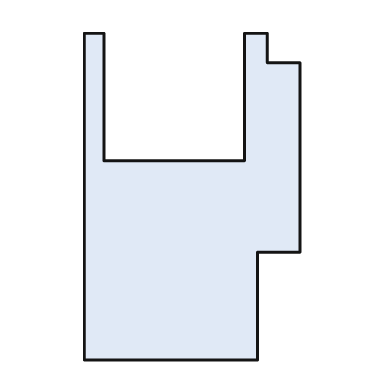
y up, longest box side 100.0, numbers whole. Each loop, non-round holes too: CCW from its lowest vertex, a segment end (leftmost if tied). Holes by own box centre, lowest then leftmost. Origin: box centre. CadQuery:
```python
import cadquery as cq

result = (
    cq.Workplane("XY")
    .moveTo(-33.0, -50.0)
    .lineTo(20.0, -50.0)
    .lineTo(20.0, -17.0)
    .lineTo(33.0, -17.0)
    .lineTo(33.0, 41.0)
    .lineTo(23.0, 41.0)
    .lineTo(23.0, 50.0)
    .lineTo(16.0, 50.0)
    .lineTo(16.0, 11.0)
    .lineTo(-27.0, 11.0)
    .lineTo(-27.0, 50.0)
    .lineTo(-33.0, 50.0)
    .close()
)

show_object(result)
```